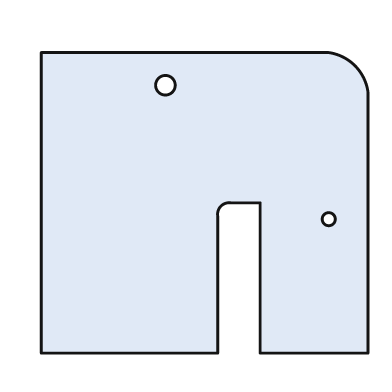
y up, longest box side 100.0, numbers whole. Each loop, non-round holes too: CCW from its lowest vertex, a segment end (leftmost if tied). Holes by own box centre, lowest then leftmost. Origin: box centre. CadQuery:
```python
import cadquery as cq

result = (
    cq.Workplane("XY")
    .moveTo(-50.0, -46.0)
    .lineTo(4.0, -46.0)
    .lineTo(4.0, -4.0)
    .threePointArc((5.0, -1.0), (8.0, 0.0))
    .lineTo(17.0, 0.0)
    .lineTo(17.0, -46.0)
    .lineTo(50.0, -46.0)
    .lineTo(50.0, 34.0)
    .threePointArc((46.0, 42.0), (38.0, 46.0))
    .lineTo(-50.0, 46.0)
    .close()
    .moveTo(38.0, -5.0)
    .circle(2.0)
    .moveTo(-12.0, 36.0)
    .circle(3.0)
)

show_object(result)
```